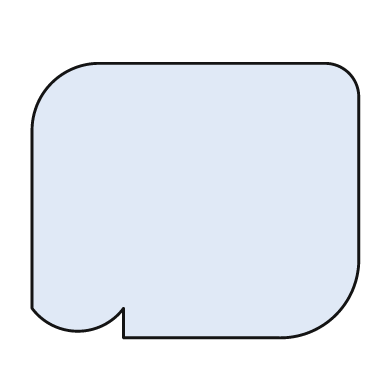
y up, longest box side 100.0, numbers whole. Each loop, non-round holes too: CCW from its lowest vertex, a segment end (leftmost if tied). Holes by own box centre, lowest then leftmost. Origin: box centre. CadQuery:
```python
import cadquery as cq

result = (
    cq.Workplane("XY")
    .moveTo(-22.0, -42.0)
    .lineTo(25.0, -42.0)
    .threePointArc((43.0, -35.0), (50.0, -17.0))
    .lineTo(50.0, 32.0)
    .threePointArc((47.0, 39.0), (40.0, 42.0))
    .lineTo(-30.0, 42.0)
    .threePointArc((-44.0, 36.0), (-50.0, 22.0))
    .lineTo(-50.0, -33.0)
    .threePointArc((-36.0, -40.0), (-22.0, -33.0))
    .close()
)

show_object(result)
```